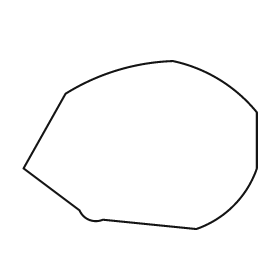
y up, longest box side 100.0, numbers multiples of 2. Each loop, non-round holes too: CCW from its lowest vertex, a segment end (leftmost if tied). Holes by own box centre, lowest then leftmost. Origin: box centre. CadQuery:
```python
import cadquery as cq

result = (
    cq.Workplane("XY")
    .moveTo(24.0, -36.0)
    .threePointArc((40.0, -26.0), (50.0, -10.0))
    .lineTo(50.0, 14.0)
    .threePointArc((34.0, 28.0), (14.0, 36.0))
    .threePointArc((-10.0, 32.0), (-32.0, 22.0))
    .lineTo(-50.0, -10.0)
    .lineTo(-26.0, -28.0)
    .threePointArc((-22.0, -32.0), (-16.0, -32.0))
    .close()
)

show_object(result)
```